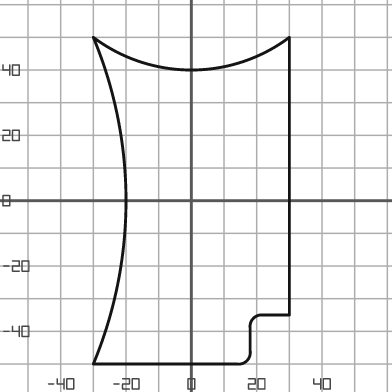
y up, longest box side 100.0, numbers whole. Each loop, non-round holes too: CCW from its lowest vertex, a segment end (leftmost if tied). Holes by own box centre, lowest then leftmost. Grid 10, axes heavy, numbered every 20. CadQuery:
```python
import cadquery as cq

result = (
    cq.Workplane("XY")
    .moveTo(-30.0, -50.0)
    .lineTo(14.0, -50.0)
    .threePointArc((17.0, -49.0), (18.0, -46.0))
    .lineTo(18.0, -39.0)
    .threePointArc((19.0, -36.0), (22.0, -35.0))
    .lineTo(30.0, -35.0)
    .lineTo(30.0, 50.0)
    .threePointArc((0.0, 40.0), (-30.0, 50.0))
    .threePointArc((-20.0, 0.0), (-30.0, -50.0))
    .close()
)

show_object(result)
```